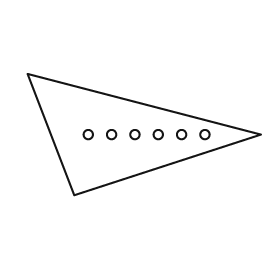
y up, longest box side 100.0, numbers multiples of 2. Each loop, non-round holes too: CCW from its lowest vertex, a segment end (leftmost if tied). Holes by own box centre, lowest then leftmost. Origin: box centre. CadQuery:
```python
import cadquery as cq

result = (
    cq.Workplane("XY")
    .moveTo(-30.0, -26.0)
    .lineTo(50.0, 0.0)
    .lineTo(-50.0, 26.0)
    .close()
    .moveTo(-24.0, 0.0)
    .circle(2.0)
    .moveTo(-14.0, 0.0)
    .circle(2.0)
    .moveTo(-4.0, 0.0)
    .circle(2.0)
    .moveTo(6.0, 0.0)
    .circle(2.0)
    .moveTo(16.0, 0.0)
    .circle(2.0)
    .moveTo(26.0, 0.0)
    .circle(2.0)
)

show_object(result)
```